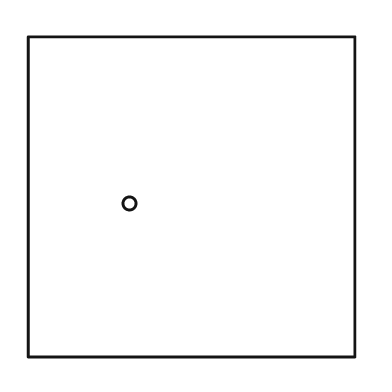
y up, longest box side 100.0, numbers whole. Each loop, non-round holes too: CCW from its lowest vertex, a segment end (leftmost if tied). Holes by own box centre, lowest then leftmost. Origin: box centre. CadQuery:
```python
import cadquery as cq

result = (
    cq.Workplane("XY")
    .moveTo(-50.0, -49.0)
    .lineTo(50.0, -49.0)
    .lineTo(50.0, 49.0)
    .lineTo(-50.0, 49.0)
    .close()
    .moveTo(-19.0, -2.0)
    .circle(2.0)
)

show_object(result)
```